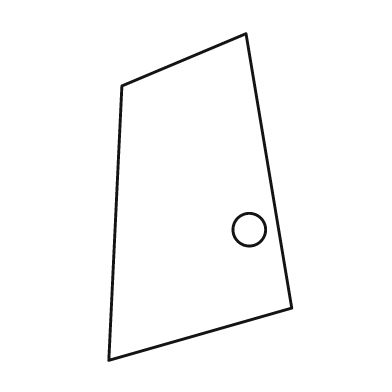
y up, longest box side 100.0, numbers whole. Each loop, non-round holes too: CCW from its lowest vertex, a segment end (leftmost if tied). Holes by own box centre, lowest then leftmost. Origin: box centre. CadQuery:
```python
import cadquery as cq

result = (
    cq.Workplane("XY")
    .moveTo(-28.0, -50.0)
    .lineTo(28.0, -34.0)
    .lineTo(14.0, 50.0)
    .lineTo(-24.0, 34.0)
    .close()
    .moveTo(15.0, -10.0)
    .circle(5.0)
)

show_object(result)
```